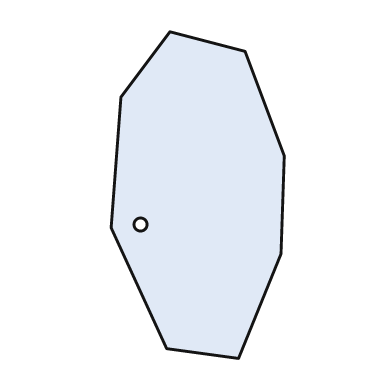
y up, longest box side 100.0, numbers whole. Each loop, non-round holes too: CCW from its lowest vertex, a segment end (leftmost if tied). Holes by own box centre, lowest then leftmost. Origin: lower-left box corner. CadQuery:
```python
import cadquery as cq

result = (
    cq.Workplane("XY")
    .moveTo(39.0, 0.0)
    .lineTo(52.0, 32.0)
    .lineTo(53.0, 62.0)
    .lineTo(41.0, 94.0)
    .lineTo(18.0, 100.0)
    .lineTo(3.0, 80.0)
    .lineTo(0.0, 40.0)
    .lineTo(17.0, 3.0)
    .close()
    .moveTo(9.0, 41.0)
    .circle(2.0)
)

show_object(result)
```